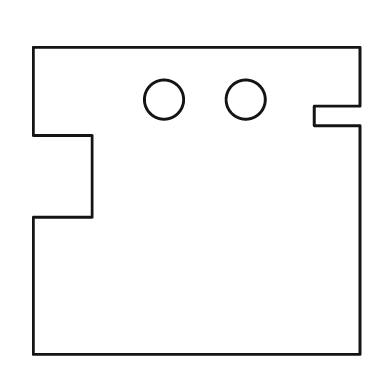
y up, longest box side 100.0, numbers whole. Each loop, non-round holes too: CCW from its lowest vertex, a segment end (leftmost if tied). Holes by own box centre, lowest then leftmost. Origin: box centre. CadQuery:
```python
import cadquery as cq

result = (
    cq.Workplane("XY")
    .moveTo(-50.0, -47.0)
    .lineTo(50.0, -47.0)
    .lineTo(50.0, 23.0)
    .lineTo(36.0, 23.0)
    .lineTo(36.0, 29.0)
    .lineTo(50.0, 29.0)
    .lineTo(50.0, 47.0)
    .lineTo(-50.0, 47.0)
    .lineTo(-50.0, 20.0)
    .lineTo(-32.0, 20.0)
    .lineTo(-32.0, -5.0)
    .lineTo(-50.0, -5.0)
    .close()
    .moveTo(-10.0, 31.0)
    .circle(6.0)
    .moveTo(15.0, 31.0)
    .circle(6.0)
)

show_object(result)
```